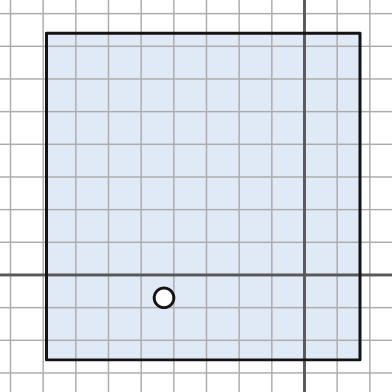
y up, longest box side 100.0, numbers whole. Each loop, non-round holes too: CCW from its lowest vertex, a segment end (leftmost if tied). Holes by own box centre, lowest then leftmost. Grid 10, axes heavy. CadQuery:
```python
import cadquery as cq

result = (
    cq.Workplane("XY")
    .moveTo(-79.0, -26.0)
    .lineTo(17.0, -26.0)
    .lineTo(17.0, 74.0)
    .lineTo(-79.0, 74.0)
    .close()
    .moveTo(-43.0, -7.0)
    .circle(3.0)
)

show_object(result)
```